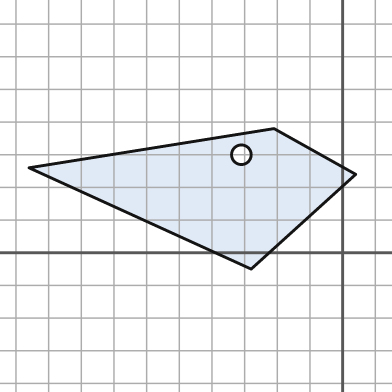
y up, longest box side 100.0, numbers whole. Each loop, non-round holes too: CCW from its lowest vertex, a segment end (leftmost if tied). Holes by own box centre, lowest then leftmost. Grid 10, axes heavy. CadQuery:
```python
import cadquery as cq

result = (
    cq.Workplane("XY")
    .moveTo(-28.0, -5.0)
    .lineTo(4.0, 24.0)
    .lineTo(-21.0, 38.0)
    .lineTo(-96.0, 26.0)
    .close()
    .moveTo(-31.0, 30.0)
    .circle(3.0)
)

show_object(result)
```